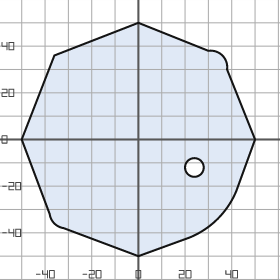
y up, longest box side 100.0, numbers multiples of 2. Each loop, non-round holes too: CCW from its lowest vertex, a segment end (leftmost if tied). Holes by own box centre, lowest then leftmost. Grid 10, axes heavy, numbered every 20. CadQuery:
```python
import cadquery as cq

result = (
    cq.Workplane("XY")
    .moveTo(0.0, -50.0)
    .lineTo(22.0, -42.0)
    .threePointArc((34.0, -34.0), (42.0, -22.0))
    .lineTo(50.0, 0.0)
    .lineTo(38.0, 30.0)
    .threePointArc((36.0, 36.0), (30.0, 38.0))
    .lineTo(0.0, 50.0)
    .lineTo(-36.0, 36.0)
    .lineTo(-50.0, 0.0)
    .lineTo(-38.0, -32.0)
    .threePointArc((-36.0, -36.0), (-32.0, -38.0))
    .close()
    .moveTo(24.0, -12.0)
    .circle(4.0)
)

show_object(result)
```